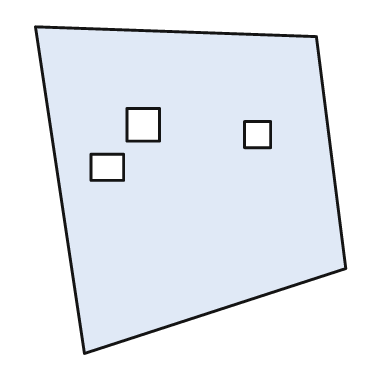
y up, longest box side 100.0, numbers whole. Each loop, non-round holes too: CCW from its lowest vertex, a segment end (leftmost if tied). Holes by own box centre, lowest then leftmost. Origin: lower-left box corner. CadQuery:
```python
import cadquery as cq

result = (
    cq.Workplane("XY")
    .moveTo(15.0, 0.0)
    .lineTo(95.0, 26.0)
    .lineTo(86.0, 97.0)
    .lineTo(0.0, 100.0)
    .close()
    .moveTo(17.0, 53.0)
    .lineTo(27.0, 53.0)
    .lineTo(27.0, 61.0)
    .lineTo(17.0, 61.0)
    .close()
    .moveTo(64.0, 63.0)
    .lineTo(72.0, 63.0)
    .lineTo(72.0, 71.0)
    .lineTo(64.0, 71.0)
    .close()
    .moveTo(28.0, 65.0)
    .lineTo(38.0, 65.0)
    .lineTo(38.0, 75.0)
    .lineTo(28.0, 75.0)
    .close()
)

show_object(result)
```